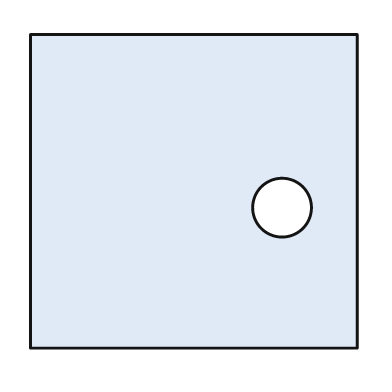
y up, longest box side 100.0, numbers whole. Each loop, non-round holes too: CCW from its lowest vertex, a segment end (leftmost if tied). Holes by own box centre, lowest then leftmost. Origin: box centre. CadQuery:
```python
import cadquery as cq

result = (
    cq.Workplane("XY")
    .moveTo(-50.0, -48.0)
    .lineTo(50.0, -48.0)
    .lineTo(50.0, 48.0)
    .lineTo(-50.0, 48.0)
    .close()
    .moveTo(27.0, -5.0)
    .circle(9.0)
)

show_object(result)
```